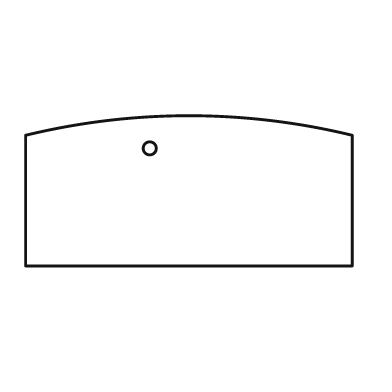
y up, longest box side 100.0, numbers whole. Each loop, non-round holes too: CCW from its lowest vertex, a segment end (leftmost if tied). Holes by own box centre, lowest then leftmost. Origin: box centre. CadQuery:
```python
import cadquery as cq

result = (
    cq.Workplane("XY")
    .moveTo(-50.0, -23.0)
    .lineTo(50.0, -23.0)
    .lineTo(50.0, 17.0)
    .threePointArc((0.0, 23.0), (-50.0, 17.0))
    .close()
    .moveTo(-12.0, 13.0)
    .circle(2.0)
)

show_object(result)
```